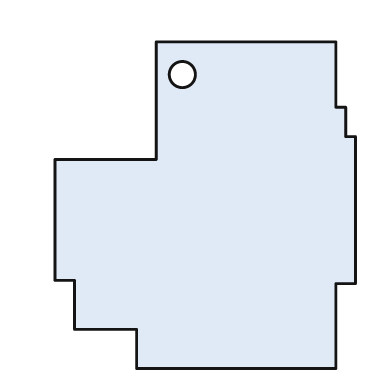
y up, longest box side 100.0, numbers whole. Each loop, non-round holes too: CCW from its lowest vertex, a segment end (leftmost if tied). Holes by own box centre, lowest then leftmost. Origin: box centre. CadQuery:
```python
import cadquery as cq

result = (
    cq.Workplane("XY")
    .moveTo(-21.0, -50.0)
    .lineTo(40.0, -50.0)
    .lineTo(40.0, -24.0)
    .lineTo(46.0, -24.0)
    .lineTo(46.0, 21.0)
    .lineTo(43.0, 21.0)
    .lineTo(43.0, 30.0)
    .lineTo(40.0, 30.0)
    .lineTo(40.0, 50.0)
    .lineTo(-15.0, 50.0)
    .lineTo(-15.0, 14.0)
    .lineTo(-46.0, 14.0)
    .lineTo(-46.0, -23.0)
    .lineTo(-40.0, -23.0)
    .lineTo(-40.0, -38.0)
    .lineTo(-21.0, -38.0)
    .close()
    .moveTo(-7.0, 40.0)
    .circle(4.0)
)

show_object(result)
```